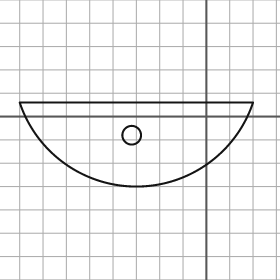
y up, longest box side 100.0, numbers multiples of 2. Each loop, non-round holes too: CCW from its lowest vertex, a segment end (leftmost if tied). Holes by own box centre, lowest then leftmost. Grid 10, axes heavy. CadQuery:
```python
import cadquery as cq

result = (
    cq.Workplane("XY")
    .moveTo(-80.0, 6.0)
    .threePointArc((-30.0, -30.0), (20.0, 6.0))
    .close()
    .moveTo(-32.0, -8.0)
    .circle(4.0)
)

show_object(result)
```